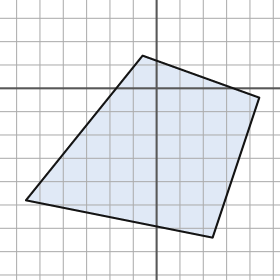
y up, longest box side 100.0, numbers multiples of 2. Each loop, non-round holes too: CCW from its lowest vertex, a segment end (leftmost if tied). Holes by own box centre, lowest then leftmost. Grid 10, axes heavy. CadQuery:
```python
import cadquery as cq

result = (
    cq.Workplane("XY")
    .moveTo(24.0, -64.0)
    .lineTo(44.0, -4.0)
    .lineTo(-6.0, 14.0)
    .lineTo(-56.0, -48.0)
    .close()
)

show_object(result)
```